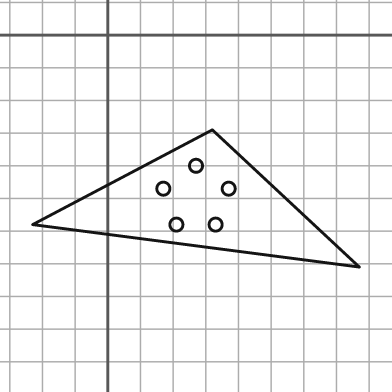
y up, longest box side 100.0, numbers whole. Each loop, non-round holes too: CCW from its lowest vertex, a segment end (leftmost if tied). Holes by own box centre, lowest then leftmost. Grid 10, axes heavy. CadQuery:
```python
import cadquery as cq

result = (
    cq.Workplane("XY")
    .moveTo(77.0, -71.0)
    .lineTo(32.0, -29.0)
    .lineTo(-23.0, -58.0)
    .close()
    .moveTo(21.0, -58.0)
    .circle(2.0)
    .moveTo(33.0, -58.0)
    .circle(2.0)
    .moveTo(17.0, -47.0)
    .circle(2.0)
    .moveTo(37.0, -47.0)
    .circle(2.0)
    .moveTo(27.0, -40.0)
    .circle(2.0)
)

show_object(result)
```